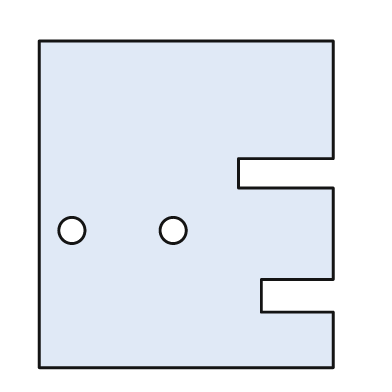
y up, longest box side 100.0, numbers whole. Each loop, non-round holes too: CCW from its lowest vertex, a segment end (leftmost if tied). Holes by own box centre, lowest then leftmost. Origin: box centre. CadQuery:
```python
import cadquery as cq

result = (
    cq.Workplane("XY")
    .moveTo(-45.0, -50.0)
    .lineTo(45.0, -50.0)
    .lineTo(45.0, -33.0)
    .lineTo(23.0, -33.0)
    .lineTo(23.0, -23.0)
    .lineTo(45.0, -23.0)
    .lineTo(45.0, 5.0)
    .lineTo(16.0, 5.0)
    .lineTo(16.0, 14.0)
    .lineTo(45.0, 14.0)
    .lineTo(45.0, 50.0)
    .lineTo(-45.0, 50.0)
    .close()
    .moveTo(-35.0, -8.0)
    .circle(4.0)
    .moveTo(-4.0, -8.0)
    .circle(4.0)
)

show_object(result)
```